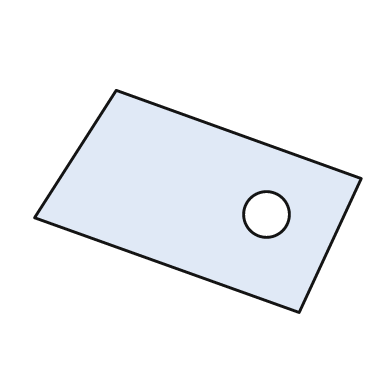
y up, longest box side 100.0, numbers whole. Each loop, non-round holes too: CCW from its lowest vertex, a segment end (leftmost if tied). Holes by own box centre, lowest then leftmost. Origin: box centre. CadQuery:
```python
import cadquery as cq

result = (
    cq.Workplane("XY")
    .moveTo(31.0, -34.0)
    .lineTo(50.0, 7.0)
    .lineTo(-25.0, 34.0)
    .lineTo(-50.0, -5.0)
    .close()
    .moveTo(21.0, -4.0)
    .circle(7.0)
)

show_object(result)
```